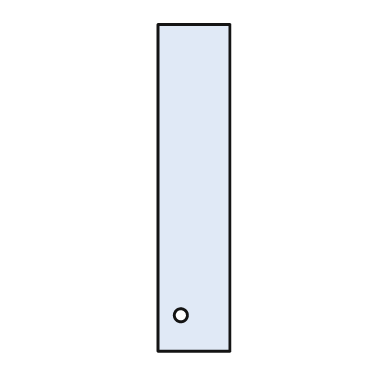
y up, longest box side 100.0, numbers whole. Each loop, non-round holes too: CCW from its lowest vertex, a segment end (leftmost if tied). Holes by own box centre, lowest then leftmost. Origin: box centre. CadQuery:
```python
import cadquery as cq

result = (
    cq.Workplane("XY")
    .moveTo(-11.0, -50.0)
    .lineTo(11.0, -50.0)
    .lineTo(11.0, 50.0)
    .lineTo(-11.0, 50.0)
    .close()
    .moveTo(-4.0, -39.0)
    .circle(2.0)
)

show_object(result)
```